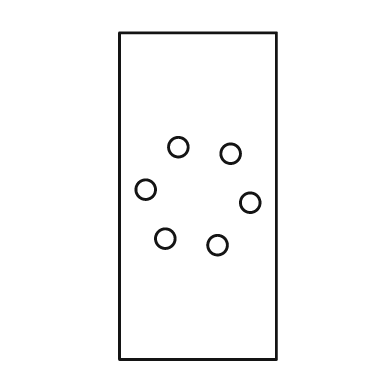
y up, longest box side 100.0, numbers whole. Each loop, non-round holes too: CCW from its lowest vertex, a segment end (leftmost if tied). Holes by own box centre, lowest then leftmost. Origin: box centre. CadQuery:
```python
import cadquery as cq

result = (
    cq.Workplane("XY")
    .moveTo(-24.0, -50.0)
    .lineTo(24.0, -50.0)
    .lineTo(24.0, 50.0)
    .lineTo(-24.0, 50.0)
    .close()
    .moveTo(6.0, -15.0)
    .circle(3.0)
    .moveTo(-10.0, -13.0)
    .circle(3.0)
    .moveTo(16.0, -2.0)
    .circle(3.0)
    .moveTo(-16.0, 2.0)
    .circle(3.0)
    .moveTo(10.0, 13.0)
    .circle(3.0)
    .moveTo(-6.0, 15.0)
    .circle(3.0)
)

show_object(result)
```